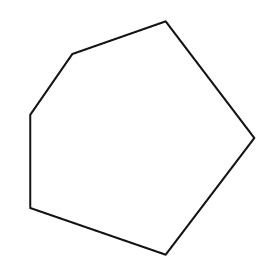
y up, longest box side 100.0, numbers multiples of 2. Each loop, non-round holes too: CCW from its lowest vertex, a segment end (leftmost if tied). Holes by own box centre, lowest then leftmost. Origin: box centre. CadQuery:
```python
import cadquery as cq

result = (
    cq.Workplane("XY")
    .moveTo(10.0, -50.0)
    .lineTo(48.0, 0.0)
    .lineTo(10.0, 50.0)
    .lineTo(-30.0, 36.0)
    .lineTo(-48.0, 10.0)
    .lineTo(-48.0, -30.0)
    .close()
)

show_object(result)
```